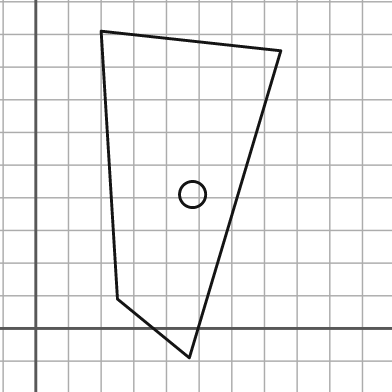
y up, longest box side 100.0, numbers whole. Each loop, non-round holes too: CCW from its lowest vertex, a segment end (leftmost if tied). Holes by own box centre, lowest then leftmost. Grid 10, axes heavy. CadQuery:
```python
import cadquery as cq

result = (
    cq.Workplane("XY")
    .moveTo(47.0, -9.0)
    .lineTo(75.0, 85.0)
    .lineTo(20.0, 91.0)
    .lineTo(25.0, 9.0)
    .close()
    .moveTo(48.0, 41.0)
    .circle(4.0)
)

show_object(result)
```